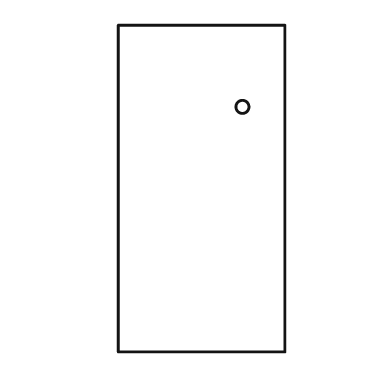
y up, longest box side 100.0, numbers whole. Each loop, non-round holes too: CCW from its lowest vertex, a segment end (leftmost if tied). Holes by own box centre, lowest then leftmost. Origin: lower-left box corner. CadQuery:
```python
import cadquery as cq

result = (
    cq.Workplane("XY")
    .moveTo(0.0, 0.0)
    .lineTo(51.0, 0.0)
    .lineTo(51.0, 100.0)
    .lineTo(0.0, 100.0)
    .close()
    .moveTo(38.0, 75.0)
    .circle(2.0)
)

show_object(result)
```